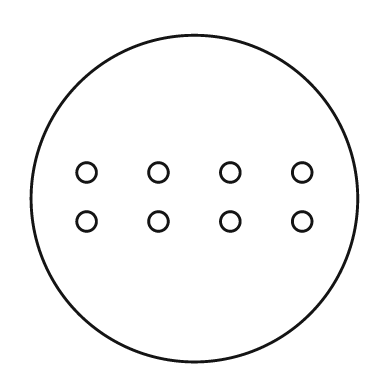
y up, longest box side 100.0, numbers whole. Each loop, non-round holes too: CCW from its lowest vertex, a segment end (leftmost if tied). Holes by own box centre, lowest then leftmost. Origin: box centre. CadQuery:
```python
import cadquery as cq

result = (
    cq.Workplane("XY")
    .moveTo(0.0, 0.0)
    .circle(50.0)
    .moveTo(-33.0, -7.0)
    .circle(3.0)
    .moveTo(-11.0, -7.0)
    .circle(3.0)
    .moveTo(11.0, -7.0)
    .circle(3.0)
    .moveTo(33.0, -7.0)
    .circle(3.0)
    .moveTo(-33.0, 8.0)
    .circle(3.0)
    .moveTo(-11.0, 8.0)
    .circle(3.0)
    .moveTo(11.0, 8.0)
    .circle(3.0)
    .moveTo(33.0, 8.0)
    .circle(3.0)
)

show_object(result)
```